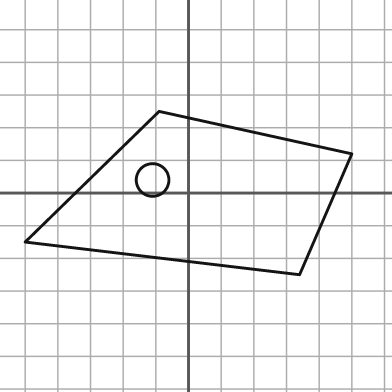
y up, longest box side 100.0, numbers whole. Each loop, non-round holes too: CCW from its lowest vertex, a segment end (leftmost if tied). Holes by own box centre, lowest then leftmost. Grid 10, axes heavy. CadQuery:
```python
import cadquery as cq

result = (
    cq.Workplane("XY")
    .moveTo(34.0, -25.0)
    .lineTo(50.0, 12.0)
    .lineTo(-9.0, 25.0)
    .lineTo(-50.0, -15.0)
    .close()
    .moveTo(-11.0, 4.0)
    .circle(5.0)
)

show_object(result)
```